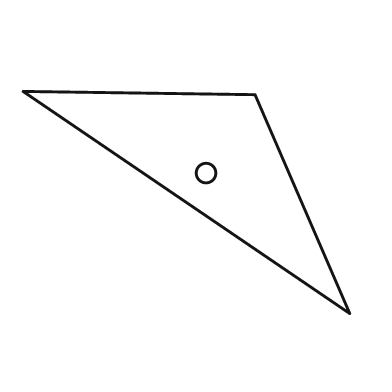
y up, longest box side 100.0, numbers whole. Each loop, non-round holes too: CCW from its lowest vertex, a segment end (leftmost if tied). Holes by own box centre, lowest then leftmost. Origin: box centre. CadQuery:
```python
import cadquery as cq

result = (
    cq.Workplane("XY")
    .moveTo(50.0, -34.0)
    .lineTo(21.0, 33.0)
    .lineTo(-50.0, 34.0)
    .close()
    .moveTo(6.0, 9.0)
    .circle(3.0)
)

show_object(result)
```